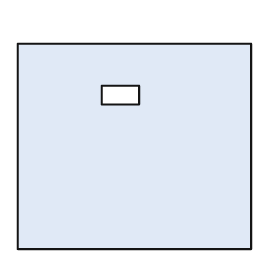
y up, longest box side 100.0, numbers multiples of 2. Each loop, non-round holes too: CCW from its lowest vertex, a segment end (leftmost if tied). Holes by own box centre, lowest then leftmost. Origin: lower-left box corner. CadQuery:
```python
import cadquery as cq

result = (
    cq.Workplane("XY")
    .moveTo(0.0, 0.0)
    .lineTo(100.0, 0.0)
    .lineTo(100.0, 88.0)
    .lineTo(0.0, 88.0)
    .close()
    .moveTo(36.0, 62.0)
    .lineTo(52.0, 62.0)
    .lineTo(52.0, 70.0)
    .lineTo(36.0, 70.0)
    .close()
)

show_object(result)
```